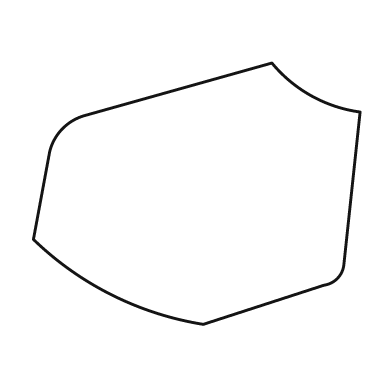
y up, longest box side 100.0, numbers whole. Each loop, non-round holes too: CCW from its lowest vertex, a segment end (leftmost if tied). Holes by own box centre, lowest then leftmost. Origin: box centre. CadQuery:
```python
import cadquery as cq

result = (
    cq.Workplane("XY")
    .moveTo(2.0, -40.0)
    .lineTo(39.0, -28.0)
    .threePointArc((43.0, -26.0), (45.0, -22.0))
    .lineTo(50.0, 25.0)
    .threePointArc((35.0, 30.0), (23.0, 40.0))
    .lineTo(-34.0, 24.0)
    .threePointArc((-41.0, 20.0), (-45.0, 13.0))
    .lineTo(-50.0, -14.0)
    .threePointArc((-26.0, -31.0), (2.0, -40.0))
    .close()
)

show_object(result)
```